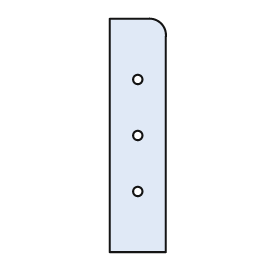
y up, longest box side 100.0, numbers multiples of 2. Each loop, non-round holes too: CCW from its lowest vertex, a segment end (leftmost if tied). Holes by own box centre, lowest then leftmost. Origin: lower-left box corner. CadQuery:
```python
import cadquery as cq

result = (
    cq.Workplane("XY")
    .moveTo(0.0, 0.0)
    .lineTo(24.0, 0.0)
    .lineTo(24.0, 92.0)
    .threePointArc((22.0, 98.0), (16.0, 100.0))
    .lineTo(0.0, 100.0)
    .close()
    .moveTo(12.0, 26.0)
    .circle(2.0)
    .moveTo(12.0, 50.0)
    .circle(2.0)
    .moveTo(12.0, 74.0)
    .circle(2.0)
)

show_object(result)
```